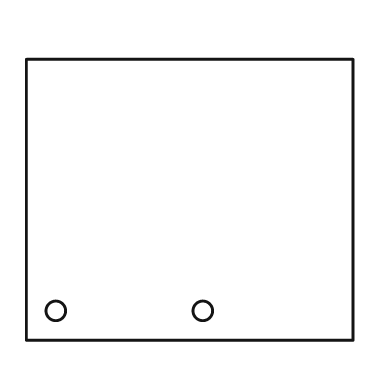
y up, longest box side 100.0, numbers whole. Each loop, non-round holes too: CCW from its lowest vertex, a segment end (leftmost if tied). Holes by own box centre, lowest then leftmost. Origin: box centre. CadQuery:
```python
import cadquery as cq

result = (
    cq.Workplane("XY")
    .moveTo(-50.0, -43.0)
    .lineTo(50.0, -43.0)
    .lineTo(50.0, 43.0)
    .lineTo(-50.0, 43.0)
    .close()
    .moveTo(-41.0, -34.0)
    .circle(3.0)
    .moveTo(4.0, -34.0)
    .circle(3.0)
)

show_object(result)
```